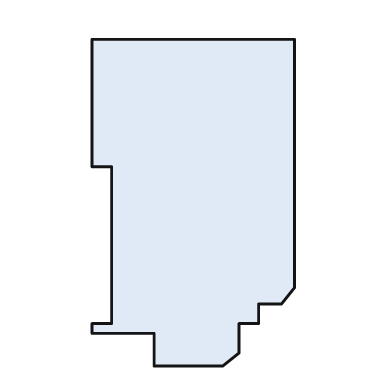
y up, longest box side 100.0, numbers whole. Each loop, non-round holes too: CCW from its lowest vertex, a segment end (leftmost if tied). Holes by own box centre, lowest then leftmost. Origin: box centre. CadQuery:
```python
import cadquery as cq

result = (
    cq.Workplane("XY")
    .moveTo(-12.0, -50.0)
    .lineTo(9.0, -50.0)
    .lineTo(14.0, -46.0)
    .lineTo(14.0, -37.0)
    .lineTo(20.0, -37.0)
    .lineTo(20.0, -31.0)
    .lineTo(27.0, -31.0)
    .lineTo(31.0, -26.0)
    .lineTo(31.0, 50.0)
    .lineTo(-31.0, 50.0)
    .lineTo(-31.0, 11.0)
    .lineTo(-25.0, 11.0)
    .lineTo(-25.0, -37.0)
    .lineTo(-31.0, -37.0)
    .lineTo(-31.0, -40.0)
    .lineTo(-12.0, -40.0)
    .close()
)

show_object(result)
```